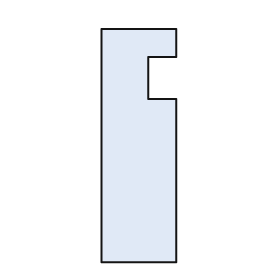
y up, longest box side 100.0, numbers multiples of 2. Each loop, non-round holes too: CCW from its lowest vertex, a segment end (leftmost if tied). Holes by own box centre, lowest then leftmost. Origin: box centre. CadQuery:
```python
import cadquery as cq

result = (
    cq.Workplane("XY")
    .moveTo(-16.0, -50.0)
    .lineTo(16.0, -50.0)
    .lineTo(16.0, 20.0)
    .lineTo(4.0, 20.0)
    .lineTo(4.0, 38.0)
    .lineTo(16.0, 38.0)
    .lineTo(16.0, 50.0)
    .lineTo(-16.0, 50.0)
    .close()
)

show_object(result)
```